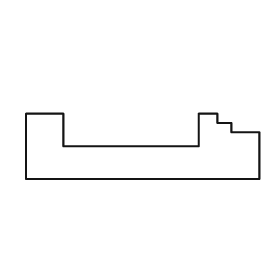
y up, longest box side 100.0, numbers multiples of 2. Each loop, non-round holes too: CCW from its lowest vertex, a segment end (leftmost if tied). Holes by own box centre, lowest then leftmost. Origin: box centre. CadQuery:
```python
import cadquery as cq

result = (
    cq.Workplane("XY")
    .moveTo(-50.0, -14.0)
    .lineTo(50.0, -14.0)
    .lineTo(50.0, 6.0)
    .lineTo(38.0, 6.0)
    .lineTo(38.0, 10.0)
    .lineTo(32.0, 10.0)
    .lineTo(32.0, 14.0)
    .lineTo(24.0, 14.0)
    .lineTo(24.0, 0.0)
    .lineTo(-34.0, 0.0)
    .lineTo(-34.0, 14.0)
    .lineTo(-50.0, 14.0)
    .close()
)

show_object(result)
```